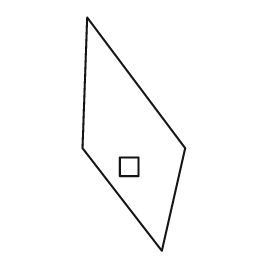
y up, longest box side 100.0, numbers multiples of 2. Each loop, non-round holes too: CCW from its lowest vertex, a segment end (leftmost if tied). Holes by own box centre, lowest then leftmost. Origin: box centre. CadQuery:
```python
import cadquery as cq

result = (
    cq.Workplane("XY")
    .moveTo(12.0, -50.0)
    .lineTo(22.0, -6.0)
    .lineTo(-20.0, 50.0)
    .lineTo(-22.0, -6.0)
    .close()
    .moveTo(-6.0, -18.0)
    .lineTo(2.0, -18.0)
    .lineTo(2.0, -10.0)
    .lineTo(-6.0, -10.0)
    .close()
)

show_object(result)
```